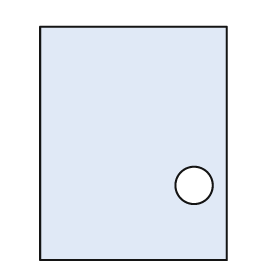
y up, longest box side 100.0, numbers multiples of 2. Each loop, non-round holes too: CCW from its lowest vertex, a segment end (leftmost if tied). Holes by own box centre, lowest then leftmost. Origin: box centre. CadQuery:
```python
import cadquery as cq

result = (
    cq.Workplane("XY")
    .moveTo(-40.0, -50.0)
    .lineTo(40.0, -50.0)
    .lineTo(40.0, 50.0)
    .lineTo(-40.0, 50.0)
    .close()
    .moveTo(26.0, -18.0)
    .circle(8.0)
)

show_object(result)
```